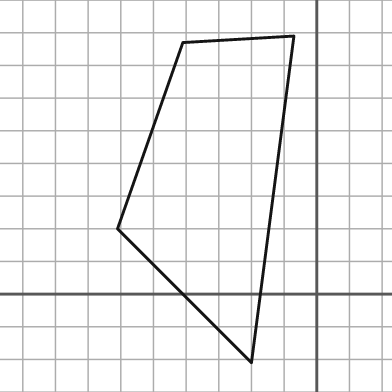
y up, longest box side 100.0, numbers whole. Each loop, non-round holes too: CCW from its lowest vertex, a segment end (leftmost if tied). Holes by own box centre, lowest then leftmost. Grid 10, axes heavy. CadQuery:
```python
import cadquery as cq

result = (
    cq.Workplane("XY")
    .moveTo(-20.0, -21.0)
    .lineTo(-7.0, 79.0)
    .lineTo(-41.0, 77.0)
    .lineTo(-61.0, 20.0)
    .close()
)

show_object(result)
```